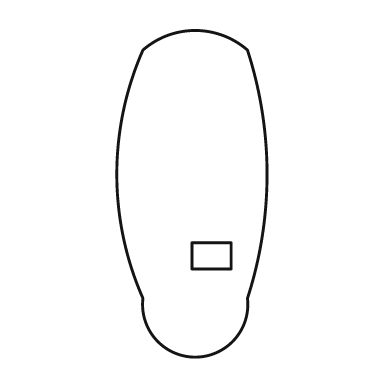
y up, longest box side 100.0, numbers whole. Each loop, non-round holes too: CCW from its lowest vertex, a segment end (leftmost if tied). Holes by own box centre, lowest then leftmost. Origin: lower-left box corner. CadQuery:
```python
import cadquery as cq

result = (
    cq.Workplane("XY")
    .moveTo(8.0, 18.0)
    .threePointArc((24.0, 0.0), (40.0, 18.0))
    .threePointArc((46.0, 56.0), (40.0, 94.0))
    .threePointArc((24.0, 100.0), (8.0, 94.0))
    .threePointArc((0.0, 56.0), (8.0, 18.0))
    .close()
    .moveTo(23.0, 27.0)
    .lineTo(35.0, 27.0)
    .lineTo(35.0, 35.0)
    .lineTo(23.0, 35.0)
    .close()
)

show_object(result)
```